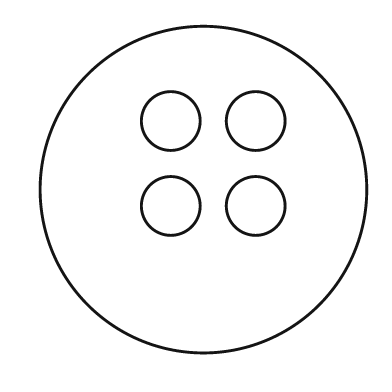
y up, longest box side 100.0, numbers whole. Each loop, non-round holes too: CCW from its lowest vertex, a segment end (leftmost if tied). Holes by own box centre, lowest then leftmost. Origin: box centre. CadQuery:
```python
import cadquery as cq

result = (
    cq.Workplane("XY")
    .moveTo(0.0, 0.0)
    .circle(50.0)
    .moveTo(-10.0, -5.0)
    .circle(9.0)
    .moveTo(16.0, -5.0)
    .circle(9.0)
    .moveTo(-10.0, 21.0)
    .circle(9.0)
    .moveTo(16.0, 21.0)
    .circle(9.0)
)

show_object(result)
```